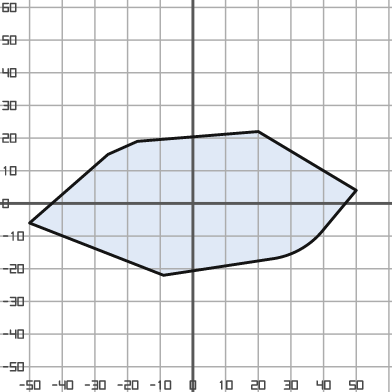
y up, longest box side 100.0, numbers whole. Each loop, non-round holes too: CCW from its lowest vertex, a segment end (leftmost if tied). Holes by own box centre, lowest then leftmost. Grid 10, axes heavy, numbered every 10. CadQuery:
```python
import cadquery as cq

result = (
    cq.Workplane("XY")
    .moveTo(-9.0, -22.0)
    .lineTo(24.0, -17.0)
    .threePointArc((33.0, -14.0), (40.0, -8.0))
    .lineTo(50.0, 4.0)
    .lineTo(20.0, 22.0)
    .lineTo(-17.0, 19.0)
    .lineTo(-26.0, 15.0)
    .lineTo(-50.0, -6.0)
    .close()
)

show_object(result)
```